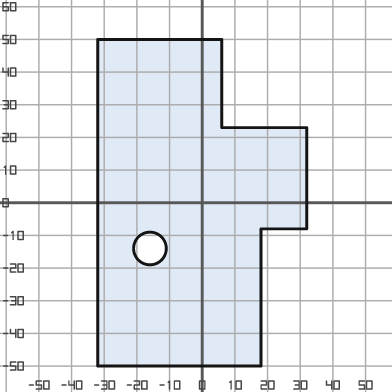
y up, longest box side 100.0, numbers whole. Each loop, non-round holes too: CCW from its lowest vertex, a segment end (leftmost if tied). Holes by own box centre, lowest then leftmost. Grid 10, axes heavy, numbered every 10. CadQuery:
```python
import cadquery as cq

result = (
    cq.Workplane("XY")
    .moveTo(-32.0, -50.0)
    .lineTo(18.0, -50.0)
    .lineTo(18.0, -8.0)
    .lineTo(32.0, -8.0)
    .lineTo(32.0, 23.0)
    .lineTo(6.0, 23.0)
    .lineTo(6.0, 50.0)
    .lineTo(-32.0, 50.0)
    .close()
    .moveTo(-16.0, -14.0)
    .circle(5.0)
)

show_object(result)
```